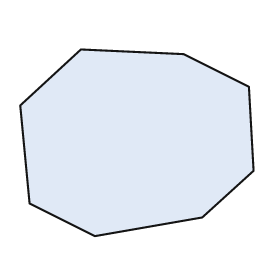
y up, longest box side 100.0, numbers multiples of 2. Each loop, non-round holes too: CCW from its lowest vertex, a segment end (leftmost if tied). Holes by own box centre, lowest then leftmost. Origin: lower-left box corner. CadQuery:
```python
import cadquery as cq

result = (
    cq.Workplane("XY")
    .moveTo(32.0, 0.0)
    .lineTo(78.0, 8.0)
    .lineTo(100.0, 28.0)
    .lineTo(98.0, 64.0)
    .lineTo(70.0, 78.0)
    .lineTo(26.0, 80.0)
    .lineTo(0.0, 56.0)
    .lineTo(4.0, 14.0)
    .close()
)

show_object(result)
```